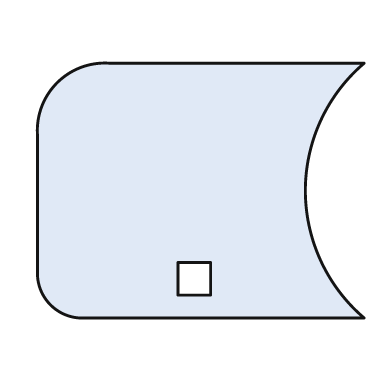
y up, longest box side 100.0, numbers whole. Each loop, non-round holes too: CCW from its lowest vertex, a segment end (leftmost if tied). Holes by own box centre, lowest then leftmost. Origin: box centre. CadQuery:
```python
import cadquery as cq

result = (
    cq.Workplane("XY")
    .moveTo(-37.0, -39.0)
    .lineTo(50.0, -39.0)
    .threePointArc((32.0, 0.0), (50.0, 39.0))
    .lineTo(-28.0, 39.0)
    .threePointArc((-44.0, 33.0), (-50.0, 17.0))
    .lineTo(-50.0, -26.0)
    .threePointArc((-46.0, -35.0), (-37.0, -39.0))
    .close()
    .moveTo(-7.0, -32.0)
    .lineTo(3.0, -32.0)
    .lineTo(3.0, -22.0)
    .lineTo(-7.0, -22.0)
    .close()
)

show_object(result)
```